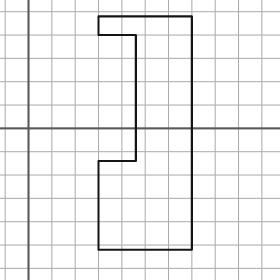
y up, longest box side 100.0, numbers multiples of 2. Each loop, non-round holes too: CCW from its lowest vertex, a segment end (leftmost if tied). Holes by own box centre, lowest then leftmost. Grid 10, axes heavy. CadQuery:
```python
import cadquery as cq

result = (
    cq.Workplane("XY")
    .moveTo(30.0, -52.0)
    .lineTo(70.0, -52.0)
    .lineTo(70.0, 48.0)
    .lineTo(30.0, 48.0)
    .lineTo(30.0, 40.0)
    .lineTo(46.0, 40.0)
    .lineTo(46.0, -14.0)
    .lineTo(30.0, -14.0)
    .close()
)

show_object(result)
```